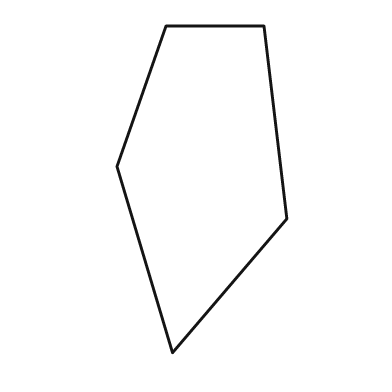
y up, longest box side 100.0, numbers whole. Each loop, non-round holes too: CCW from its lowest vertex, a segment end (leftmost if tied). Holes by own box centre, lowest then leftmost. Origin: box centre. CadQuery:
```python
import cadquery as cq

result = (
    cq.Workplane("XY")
    .moveTo(-9.0, -50.0)
    .lineTo(26.0, -9.0)
    .lineTo(19.0, 50.0)
    .lineTo(-11.0, 50.0)
    .lineTo(-26.0, 7.0)
    .close()
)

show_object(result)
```